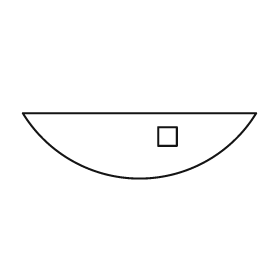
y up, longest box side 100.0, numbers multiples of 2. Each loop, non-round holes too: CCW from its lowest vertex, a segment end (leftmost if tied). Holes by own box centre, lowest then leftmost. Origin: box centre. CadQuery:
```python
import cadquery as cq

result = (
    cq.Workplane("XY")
    .moveTo(-50.0, 14.0)
    .threePointArc((0.0, -14.0), (50.0, 14.0))
    .close()
    .moveTo(8.0, 0.0)
    .lineTo(16.0, 0.0)
    .lineTo(16.0, 8.0)
    .lineTo(8.0, 8.0)
    .close()
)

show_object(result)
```